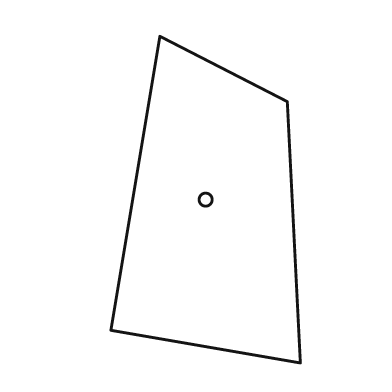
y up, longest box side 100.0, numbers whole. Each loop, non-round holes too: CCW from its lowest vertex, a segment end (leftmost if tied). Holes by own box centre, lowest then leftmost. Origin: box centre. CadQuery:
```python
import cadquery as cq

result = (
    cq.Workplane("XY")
    .moveTo(29.0, -50.0)
    .lineTo(25.0, 30.0)
    .lineTo(-14.0, 50.0)
    .lineTo(-29.0, -40.0)
    .close()
    .moveTo(0.0, 0.0)
    .circle(2.0)
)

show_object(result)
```